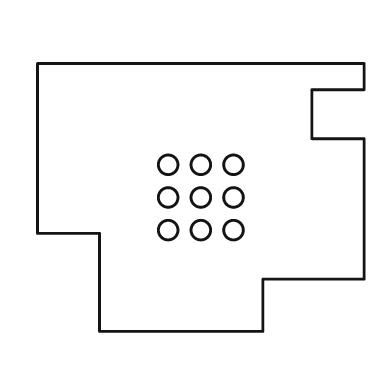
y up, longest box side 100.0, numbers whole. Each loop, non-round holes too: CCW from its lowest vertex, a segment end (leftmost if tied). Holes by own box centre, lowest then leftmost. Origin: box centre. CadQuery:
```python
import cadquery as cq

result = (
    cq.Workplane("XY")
    .moveTo(-31.0, -41.0)
    .lineTo(19.0, -41.0)
    .lineTo(19.0, -25.0)
    .lineTo(50.0, -25.0)
    .lineTo(50.0, 18.0)
    .lineTo(34.0, 18.0)
    .lineTo(34.0, 33.0)
    .lineTo(50.0, 33.0)
    .lineTo(50.0, 41.0)
    .lineTo(-50.0, 41.0)
    .lineTo(-50.0, -11.0)
    .lineTo(-31.0, -11.0)
    .close()
    .moveTo(-10.0, -10.0)
    .circle(3.0)
    .moveTo(0.0, -10.0)
    .circle(3.0)
    .moveTo(10.0, -10.0)
    .circle(3.0)
    .moveTo(-10.0, 0.0)
    .circle(3.0)
    .moveTo(0.0, 0.0)
    .circle(3.0)
    .moveTo(10.0, 0.0)
    .circle(3.0)
    .moveTo(-10.0, 10.0)
    .circle(3.0)
    .moveTo(0.0, 10.0)
    .circle(3.0)
    .moveTo(10.0, 10.0)
    .circle(3.0)
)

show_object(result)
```